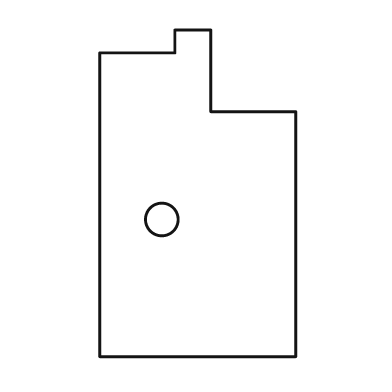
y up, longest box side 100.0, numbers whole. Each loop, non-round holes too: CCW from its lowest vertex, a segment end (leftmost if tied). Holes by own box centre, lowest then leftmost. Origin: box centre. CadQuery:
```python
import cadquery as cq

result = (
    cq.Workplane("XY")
    .moveTo(-30.0, -50.0)
    .lineTo(30.0, -50.0)
    .lineTo(30.0, 25.0)
    .lineTo(4.0, 25.0)
    .lineTo(4.0, 50.0)
    .lineTo(-7.0, 50.0)
    .lineTo(-7.0, 43.0)
    .lineTo(-30.0, 43.0)
    .close()
    .moveTo(-11.0, -8.0)
    .circle(5.0)
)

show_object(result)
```